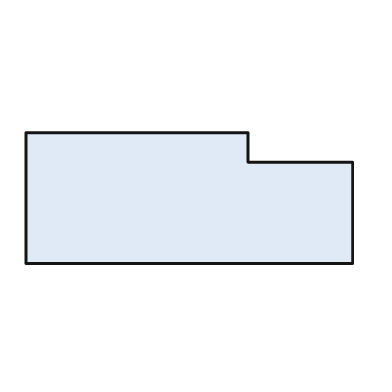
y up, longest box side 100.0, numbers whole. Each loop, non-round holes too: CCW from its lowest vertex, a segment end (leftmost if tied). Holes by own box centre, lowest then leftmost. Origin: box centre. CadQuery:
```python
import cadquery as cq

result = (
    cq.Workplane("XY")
    .moveTo(-50.0, -20.0)
    .lineTo(50.0, -20.0)
    .lineTo(50.0, 11.0)
    .lineTo(18.0, 11.0)
    .lineTo(18.0, 20.0)
    .lineTo(-50.0, 20.0)
    .close()
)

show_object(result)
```